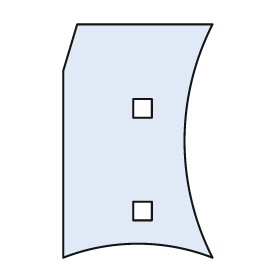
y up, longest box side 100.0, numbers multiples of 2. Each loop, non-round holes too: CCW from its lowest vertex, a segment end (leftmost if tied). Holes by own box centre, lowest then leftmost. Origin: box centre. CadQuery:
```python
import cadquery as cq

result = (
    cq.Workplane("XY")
    .moveTo(-32.0, -50.0)
    .threePointArc((0.0, -44.0), (32.0, -50.0))
    .threePointArc((20.0, 0.0), (32.0, 50.0))
    .lineTo(-26.0, 50.0)
    .lineTo(-32.0, 30.0)
    .close()
    .moveTo(-2.0, -34.0)
    .lineTo(6.0, -34.0)
    .lineTo(6.0, -26.0)
    .lineTo(-2.0, -26.0)
    .close()
    .moveTo(-2.0, 10.0)
    .lineTo(6.0, 10.0)
    .lineTo(6.0, 18.0)
    .lineTo(-2.0, 18.0)
    .close()
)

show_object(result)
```